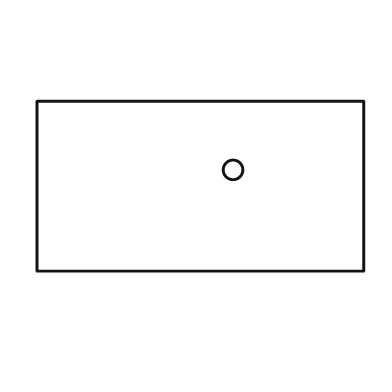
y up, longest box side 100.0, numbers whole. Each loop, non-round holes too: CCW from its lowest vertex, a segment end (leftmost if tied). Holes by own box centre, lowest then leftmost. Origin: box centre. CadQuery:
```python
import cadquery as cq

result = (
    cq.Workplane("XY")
    .moveTo(-50.0, -26.0)
    .lineTo(50.0, -26.0)
    .lineTo(50.0, 26.0)
    .lineTo(-50.0, 26.0)
    .close()
    .moveTo(10.0, 5.0)
    .circle(3.0)
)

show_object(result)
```